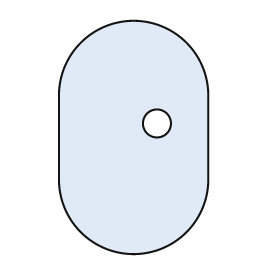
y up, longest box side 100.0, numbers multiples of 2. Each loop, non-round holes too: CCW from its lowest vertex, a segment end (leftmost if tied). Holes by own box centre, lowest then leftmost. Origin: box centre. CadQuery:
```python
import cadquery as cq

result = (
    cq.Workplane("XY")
    .moveTo(-32.0, -18.0)
    .threePointArc((0.0, -50.0), (32.0, -18.0))
    .lineTo(32.0, 18.0)
    .threePointArc((0.0, 50.0), (-32.0, 18.0))
    .close()
    .moveTo(10.0, 6.0)
    .circle(6.0)
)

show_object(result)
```